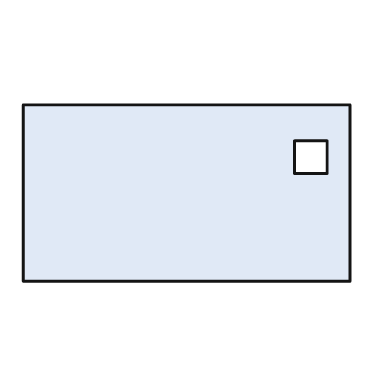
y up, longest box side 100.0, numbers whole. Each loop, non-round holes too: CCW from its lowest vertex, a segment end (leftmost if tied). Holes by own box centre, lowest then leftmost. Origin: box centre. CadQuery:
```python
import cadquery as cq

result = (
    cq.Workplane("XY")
    .moveTo(-50.0, -27.0)
    .lineTo(50.0, -27.0)
    .lineTo(50.0, 27.0)
    .lineTo(-50.0, 27.0)
    .close()
    .moveTo(33.0, 6.0)
    .lineTo(43.0, 6.0)
    .lineTo(43.0, 16.0)
    .lineTo(33.0, 16.0)
    .close()
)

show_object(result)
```